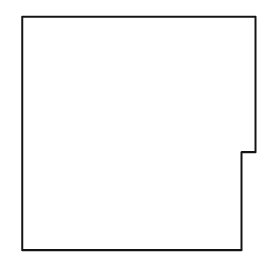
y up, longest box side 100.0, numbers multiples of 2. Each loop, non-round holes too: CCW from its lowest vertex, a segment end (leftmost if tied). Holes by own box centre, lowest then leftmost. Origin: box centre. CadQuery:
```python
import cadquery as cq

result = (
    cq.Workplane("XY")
    .moveTo(-50.0, -50.0)
    .lineTo(44.0, -50.0)
    .lineTo(44.0, -8.0)
    .lineTo(50.0, -8.0)
    .lineTo(50.0, 50.0)
    .lineTo(-50.0, 50.0)
    .close()
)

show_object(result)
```